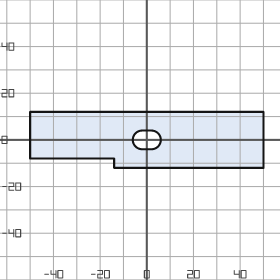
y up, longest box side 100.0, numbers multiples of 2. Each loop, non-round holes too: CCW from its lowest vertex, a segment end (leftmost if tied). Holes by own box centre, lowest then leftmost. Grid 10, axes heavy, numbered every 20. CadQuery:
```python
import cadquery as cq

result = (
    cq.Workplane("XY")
    .moveTo(-14.0, -12.0)
    .lineTo(50.0, -12.0)
    .lineTo(50.0, 12.0)
    .lineTo(-50.0, 12.0)
    .lineTo(-50.0, -8.0)
    .lineTo(-14.0, -8.0)
    .close()
    .moveTo(-2.0, -4.0)
    .lineTo(2.0, -4.0)
    .threePointArc((6.0, 0.0), (2.0, 4.0))
    .lineTo(-2.0, 4.0)
    .threePointArc((-6.0, 0.0), (-2.0, -4.0))
    .close()
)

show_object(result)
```